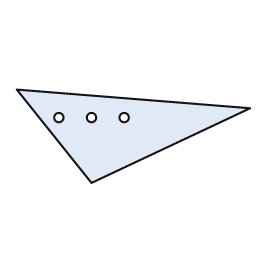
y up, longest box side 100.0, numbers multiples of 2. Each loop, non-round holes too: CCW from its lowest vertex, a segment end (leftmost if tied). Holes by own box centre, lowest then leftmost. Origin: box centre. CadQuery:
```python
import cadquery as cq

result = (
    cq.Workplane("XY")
    .moveTo(-18.0, -20.0)
    .lineTo(50.0, 12.0)
    .lineTo(-50.0, 20.0)
    .close()
    .moveTo(-32.0, 8.0)
    .circle(2.0)
    .moveTo(-18.0, 8.0)
    .circle(2.0)
    .moveTo(-4.0, 8.0)
    .circle(2.0)
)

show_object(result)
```